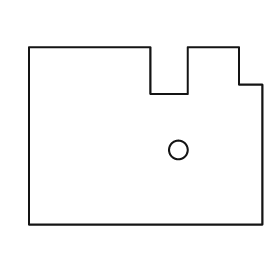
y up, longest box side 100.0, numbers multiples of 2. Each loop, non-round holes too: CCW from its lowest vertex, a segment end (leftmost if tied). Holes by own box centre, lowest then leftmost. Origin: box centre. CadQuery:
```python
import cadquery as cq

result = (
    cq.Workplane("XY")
    .moveTo(-50.0, -38.0)
    .lineTo(50.0, -38.0)
    .lineTo(50.0, 22.0)
    .lineTo(40.0, 22.0)
    .lineTo(40.0, 38.0)
    .lineTo(18.0, 38.0)
    .lineTo(18.0, 18.0)
    .lineTo(2.0, 18.0)
    .lineTo(2.0, 38.0)
    .lineTo(-50.0, 38.0)
    .close()
    .moveTo(14.0, -6.0)
    .circle(4.0)
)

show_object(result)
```